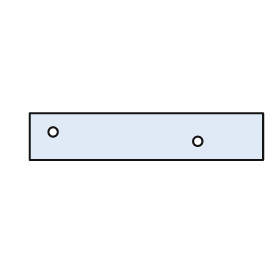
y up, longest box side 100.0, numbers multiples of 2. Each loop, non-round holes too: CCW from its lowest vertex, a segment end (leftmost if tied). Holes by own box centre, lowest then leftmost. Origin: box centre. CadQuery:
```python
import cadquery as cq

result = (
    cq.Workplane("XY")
    .moveTo(-50.0, -10.0)
    .lineTo(50.0, -10.0)
    .lineTo(50.0, 10.0)
    .lineTo(-50.0, 10.0)
    .close()
    .moveTo(22.0, -2.0)
    .circle(2.0)
    .moveTo(-40.0, 2.0)
    .circle(2.0)
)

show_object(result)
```